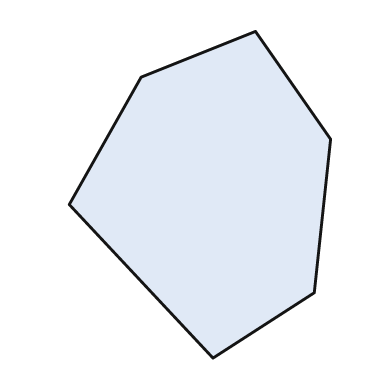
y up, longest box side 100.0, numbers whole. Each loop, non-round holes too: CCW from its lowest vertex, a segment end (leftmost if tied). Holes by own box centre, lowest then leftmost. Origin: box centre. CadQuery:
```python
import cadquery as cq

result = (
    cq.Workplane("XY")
    .moveTo(4.0, -50.0)
    .lineTo(35.0, -30.0)
    .lineTo(40.0, 17.0)
    .lineTo(17.0, 50.0)
    .lineTo(-18.0, 36.0)
    .lineTo(-40.0, -3.0)
    .close()
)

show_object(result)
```